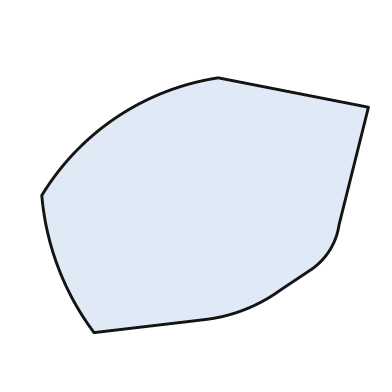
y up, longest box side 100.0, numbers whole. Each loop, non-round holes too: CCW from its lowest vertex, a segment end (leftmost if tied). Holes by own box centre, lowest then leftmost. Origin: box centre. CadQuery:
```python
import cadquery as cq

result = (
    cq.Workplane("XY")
    .moveTo(-34.0, -39.0)
    .lineTo(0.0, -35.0)
    .threePointArc((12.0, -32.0), (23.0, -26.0))
    .lineTo(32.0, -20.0)
    .threePointArc((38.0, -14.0), (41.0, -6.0))
    .lineTo(50.0, 30.0)
    .lineTo(4.0, 39.0)
    .threePointArc((-27.0, 27.0), (-50.0, 3.0))
    .threePointArc((-45.0, -19.0), (-34.0, -39.0))
    .close()
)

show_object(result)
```